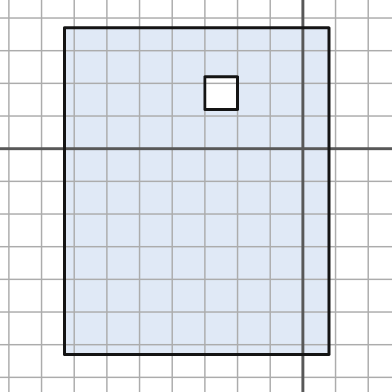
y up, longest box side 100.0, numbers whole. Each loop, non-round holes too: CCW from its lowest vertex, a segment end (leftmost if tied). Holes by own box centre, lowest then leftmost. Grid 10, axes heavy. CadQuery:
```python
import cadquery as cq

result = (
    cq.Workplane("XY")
    .moveTo(-73.0, -63.0)
    .lineTo(8.0, -63.0)
    .lineTo(8.0, 37.0)
    .lineTo(-73.0, 37.0)
    .close()
    .moveTo(-30.0, 12.0)
    .lineTo(-20.0, 12.0)
    .lineTo(-20.0, 22.0)
    .lineTo(-30.0, 22.0)
    .close()
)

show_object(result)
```